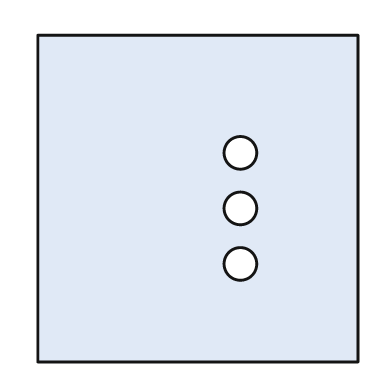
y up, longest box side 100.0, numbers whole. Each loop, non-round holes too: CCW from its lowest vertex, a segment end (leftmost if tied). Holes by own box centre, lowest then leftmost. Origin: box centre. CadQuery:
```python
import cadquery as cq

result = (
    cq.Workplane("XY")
    .moveTo(-49.0, -50.0)
    .lineTo(49.0, -50.0)
    .lineTo(49.0, 50.0)
    .lineTo(-49.0, 50.0)
    .close()
    .moveTo(13.0, -20.0)
    .circle(5.0)
    .moveTo(13.0, -3.0)
    .circle(5.0)
    .moveTo(13.0, 14.0)
    .circle(5.0)
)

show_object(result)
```